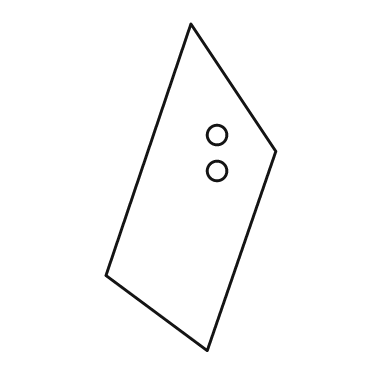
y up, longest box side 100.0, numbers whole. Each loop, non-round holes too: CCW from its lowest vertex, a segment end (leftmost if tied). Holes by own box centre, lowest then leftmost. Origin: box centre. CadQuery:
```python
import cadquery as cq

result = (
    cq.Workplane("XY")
    .moveTo(5.0, -50.0)
    .lineTo(26.0, 11.0)
    .lineTo(0.0, 50.0)
    .lineTo(-26.0, -27.0)
    .close()
    .moveTo(8.0, 5.0)
    .circle(3.0)
    .moveTo(8.0, 16.0)
    .circle(3.0)
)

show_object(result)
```